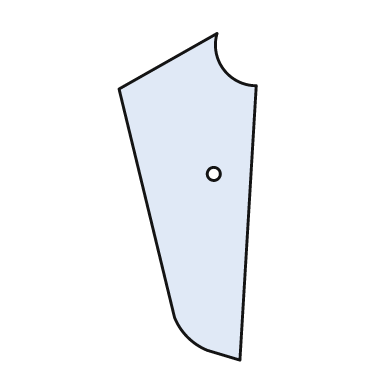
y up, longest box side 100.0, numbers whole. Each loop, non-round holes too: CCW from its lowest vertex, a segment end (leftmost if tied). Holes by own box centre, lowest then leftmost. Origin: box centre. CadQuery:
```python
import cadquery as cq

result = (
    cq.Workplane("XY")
    .moveTo(16.0, -50.0)
    .lineTo(21.0, 34.0)
    .threePointArc((11.0, 39.0), (9.0, 50.0))
    .lineTo(-21.0, 33.0)
    .lineTo(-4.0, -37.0)
    .threePointArc((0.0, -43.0), (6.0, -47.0))
    .close()
    .moveTo(8.0, 7.0)
    .circle(2.0)
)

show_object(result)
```